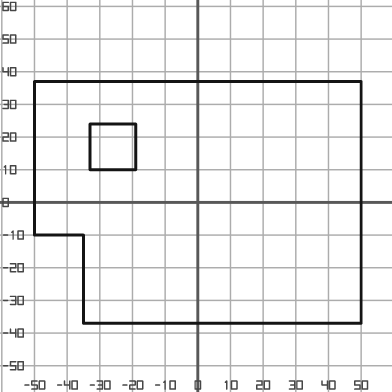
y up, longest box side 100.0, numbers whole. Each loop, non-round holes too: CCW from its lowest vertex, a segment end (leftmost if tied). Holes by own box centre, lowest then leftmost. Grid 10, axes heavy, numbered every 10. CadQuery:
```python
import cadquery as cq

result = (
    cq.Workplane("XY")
    .moveTo(-35.0, -37.0)
    .lineTo(50.0, -37.0)
    .lineTo(50.0, 37.0)
    .lineTo(-50.0, 37.0)
    .lineTo(-50.0, -10.0)
    .lineTo(-35.0, -10.0)
    .close()
    .moveTo(-33.0, 10.0)
    .lineTo(-19.0, 10.0)
    .lineTo(-19.0, 24.0)
    .lineTo(-33.0, 24.0)
    .close()
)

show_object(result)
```